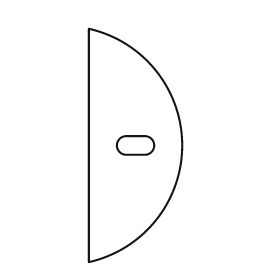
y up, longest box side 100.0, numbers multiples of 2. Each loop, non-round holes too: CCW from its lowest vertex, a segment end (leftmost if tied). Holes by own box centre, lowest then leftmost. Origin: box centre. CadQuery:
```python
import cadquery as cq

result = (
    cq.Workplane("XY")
    .moveTo(-20.0, -50.0)
    .threePointArc((20.0, 0.0), (-20.0, 50.0))
    .close()
    .moveTo(-4.0, -4.0)
    .lineTo(4.0, -4.0)
    .threePointArc((8.0, 0.0), (4.0, 4.0))
    .lineTo(-4.0, 4.0)
    .threePointArc((-8.0, 0.0), (-4.0, -4.0))
    .close()
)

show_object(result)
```